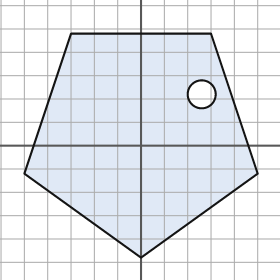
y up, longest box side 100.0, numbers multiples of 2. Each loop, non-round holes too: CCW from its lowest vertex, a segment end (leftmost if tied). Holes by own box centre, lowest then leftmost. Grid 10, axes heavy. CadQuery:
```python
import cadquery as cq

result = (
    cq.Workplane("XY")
    .moveTo(0.0, -48.0)
    .lineTo(50.0, -12.0)
    .lineTo(30.0, 48.0)
    .lineTo(-30.0, 48.0)
    .lineTo(-50.0, -12.0)
    .close()
    .moveTo(26.0, 22.0)
    .circle(6.0)
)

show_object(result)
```